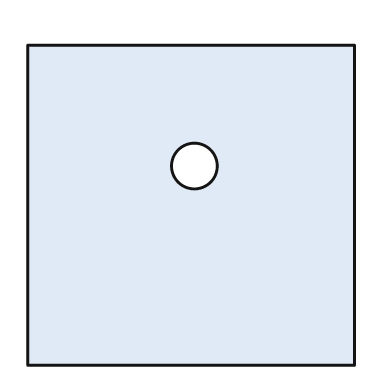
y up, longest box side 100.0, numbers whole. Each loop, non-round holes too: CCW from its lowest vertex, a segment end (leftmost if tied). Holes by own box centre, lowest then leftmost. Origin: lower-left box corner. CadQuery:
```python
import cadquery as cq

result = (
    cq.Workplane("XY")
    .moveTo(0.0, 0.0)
    .lineTo(100.0, 0.0)
    .lineTo(100.0, 98.0)
    .lineTo(0.0, 98.0)
    .close()
    .moveTo(51.0, 61.0)
    .circle(7.0)
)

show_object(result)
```